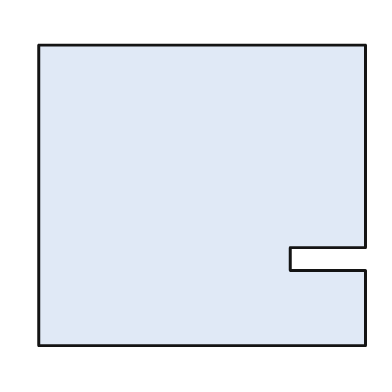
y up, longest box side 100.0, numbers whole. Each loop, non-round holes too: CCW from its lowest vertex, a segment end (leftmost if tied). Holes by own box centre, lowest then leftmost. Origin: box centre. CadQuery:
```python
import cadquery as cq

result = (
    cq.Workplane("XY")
    .moveTo(-50.0, -46.0)
    .lineTo(50.0, -46.0)
    .lineTo(50.0, -23.0)
    .lineTo(27.0, -23.0)
    .lineTo(27.0, -16.0)
    .lineTo(50.0, -16.0)
    .lineTo(50.0, 46.0)
    .lineTo(-50.0, 46.0)
    .close()
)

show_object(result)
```